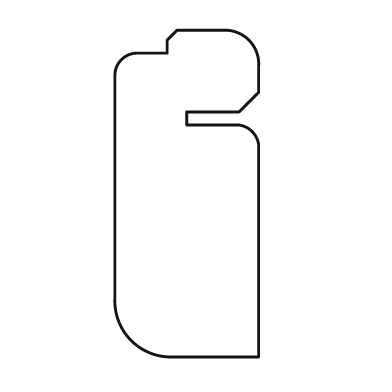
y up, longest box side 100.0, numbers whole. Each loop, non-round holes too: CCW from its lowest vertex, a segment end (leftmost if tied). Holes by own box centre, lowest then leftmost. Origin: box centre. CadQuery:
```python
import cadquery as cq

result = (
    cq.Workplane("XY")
    .moveTo(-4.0, -50.0)
    .lineTo(22.0, -50.0)
    .lineTo(22.0, 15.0)
    .threePointArc((20.0, 19.0), (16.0, 21.0))
    .lineTo(0.0, 21.0)
    .lineTo(0.0, 25.0)
    .lineTo(16.0, 25.0)
    .lineTo(22.0, 31.0)
    .lineTo(22.0, 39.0)
    .threePointArc((19.0, 47.0), (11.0, 50.0))
    .lineTo(-3.0, 50.0)
    .lineTo(-6.0, 47.0)
    .lineTo(-6.0, 43.0)
    .lineTo(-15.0, 43.0)
    .threePointArc((-20.0, 41.0), (-22.0, 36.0))
    .lineTo(-22.0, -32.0)
    .threePointArc((-17.0, -45.0), (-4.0, -50.0))
    .close()
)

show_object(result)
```